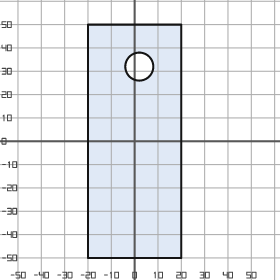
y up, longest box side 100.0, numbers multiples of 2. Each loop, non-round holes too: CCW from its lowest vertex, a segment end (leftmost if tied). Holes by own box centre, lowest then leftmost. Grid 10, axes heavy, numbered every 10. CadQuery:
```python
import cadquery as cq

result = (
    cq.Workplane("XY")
    .moveTo(-20.0, -50.0)
    .lineTo(20.0, -50.0)
    .lineTo(20.0, 50.0)
    .lineTo(-20.0, 50.0)
    .close()
    .moveTo(2.0, 32.0)
    .circle(6.0)
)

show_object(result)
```